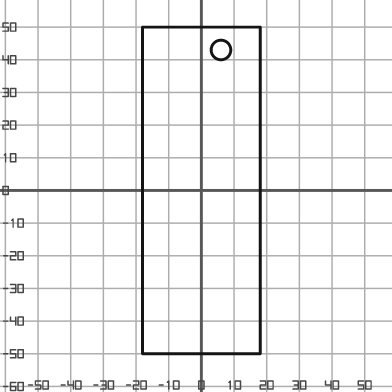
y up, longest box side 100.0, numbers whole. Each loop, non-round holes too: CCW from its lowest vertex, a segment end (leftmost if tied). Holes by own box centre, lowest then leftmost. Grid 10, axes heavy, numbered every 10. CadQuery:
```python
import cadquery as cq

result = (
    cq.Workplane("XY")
    .moveTo(-18.0, -50.0)
    .lineTo(18.0, -50.0)
    .lineTo(18.0, 50.0)
    .lineTo(-18.0, 50.0)
    .close()
    .moveTo(6.0, 43.0)
    .circle(3.0)
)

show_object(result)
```